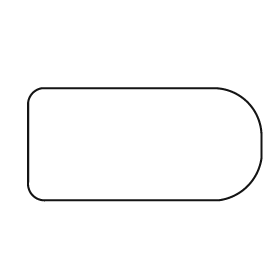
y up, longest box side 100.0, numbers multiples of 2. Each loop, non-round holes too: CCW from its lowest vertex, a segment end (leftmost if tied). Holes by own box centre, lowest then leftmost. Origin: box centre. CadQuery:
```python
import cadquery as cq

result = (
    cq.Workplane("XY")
    .moveTo(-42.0, -24.0)
    .lineTo(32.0, -24.0)
    .threePointArc((44.0, -18.0), (50.0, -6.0))
    .lineTo(50.0, 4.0)
    .threePointArc((44.0, 18.0), (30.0, 24.0))
    .lineTo(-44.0, 24.0)
    .threePointArc((-48.0, 22.0), (-50.0, 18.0))
    .lineTo(-50.0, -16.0)
    .threePointArc((-48.0, -22.0), (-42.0, -24.0))
    .close()
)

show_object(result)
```